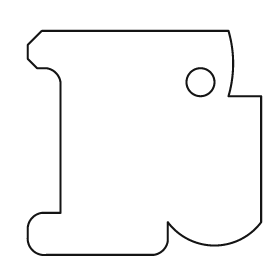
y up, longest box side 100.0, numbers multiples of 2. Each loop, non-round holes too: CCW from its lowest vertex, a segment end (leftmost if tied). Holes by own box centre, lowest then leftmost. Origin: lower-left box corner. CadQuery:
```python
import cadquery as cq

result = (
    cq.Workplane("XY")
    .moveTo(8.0, 0.0)
    .lineTo(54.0, 0.0)
    .threePointArc((58.0, 2.0), (60.0, 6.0))
    .lineTo(60.0, 14.0)
    .threePointArc((80.0, 4.0), (100.0, 14.0))
    .lineTo(100.0, 68.0)
    .lineTo(86.0, 68.0)
    .threePointArc((88.0, 82.0), (86.0, 96.0))
    .lineTo(6.0, 96.0)
    .lineTo(0.0, 90.0)
    .lineTo(0.0, 84.0)
    .lineTo(4.0, 80.0)
    .lineTo(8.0, 80.0)
    .threePointArc((12.0, 78.0), (14.0, 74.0))
    .lineTo(14.0, 18.0)
    .lineTo(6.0, 18.0)
    .threePointArc((2.0, 16.0), (0.0, 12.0))
    .lineTo(0.0, 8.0)
    .threePointArc((2.0, 2.0), (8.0, 0.0))
    .close()
    .moveTo(74.0, 74.0)
    .circle(6.0)
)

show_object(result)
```